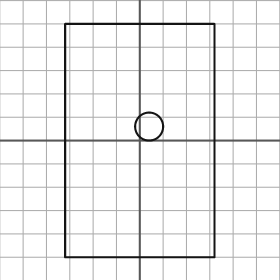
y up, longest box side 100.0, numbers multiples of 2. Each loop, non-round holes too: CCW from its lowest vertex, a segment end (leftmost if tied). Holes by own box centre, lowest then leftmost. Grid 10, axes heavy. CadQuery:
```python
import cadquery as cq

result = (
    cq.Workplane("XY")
    .moveTo(-32.0, -50.0)
    .lineTo(32.0, -50.0)
    .lineTo(32.0, 50.0)
    .lineTo(-32.0, 50.0)
    .close()
    .moveTo(4.0, 6.0)
    .circle(6.0)
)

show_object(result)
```